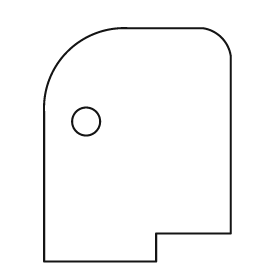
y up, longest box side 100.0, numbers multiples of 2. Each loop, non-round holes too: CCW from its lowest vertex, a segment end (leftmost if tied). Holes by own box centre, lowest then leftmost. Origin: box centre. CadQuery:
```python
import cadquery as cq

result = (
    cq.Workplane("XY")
    .moveTo(-40.0, -50.0)
    .lineTo(8.0, -50.0)
    .lineTo(8.0, -38.0)
    .lineTo(40.0, -38.0)
    .lineTo(40.0, 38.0)
    .threePointArc((36.0, 46.0), (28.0, 50.0))
    .lineTo(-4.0, 50.0)
    .threePointArc((-30.0, 40.0), (-40.0, 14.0))
    .close()
    .moveTo(-22.0, 10.0)
    .circle(6.0)
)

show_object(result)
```